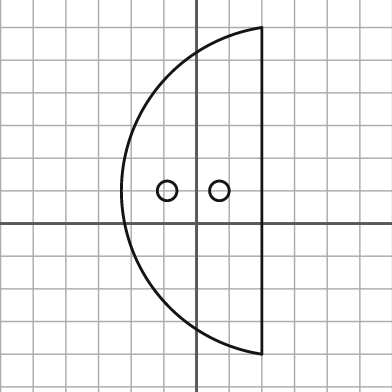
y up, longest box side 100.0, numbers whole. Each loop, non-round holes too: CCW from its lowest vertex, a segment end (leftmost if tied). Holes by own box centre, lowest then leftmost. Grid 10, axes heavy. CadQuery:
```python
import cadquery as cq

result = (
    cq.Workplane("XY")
    .moveTo(20.0, -40.0)
    .lineTo(20.0, 60.0)
    .threePointArc((-23.0, 10.0), (20.0, -40.0))
    .close()
    .moveTo(-9.0, 10.0)
    .circle(3.0)
    .moveTo(7.0, 10.0)
    .circle(3.0)
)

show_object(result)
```